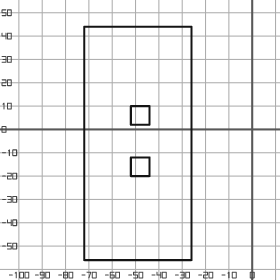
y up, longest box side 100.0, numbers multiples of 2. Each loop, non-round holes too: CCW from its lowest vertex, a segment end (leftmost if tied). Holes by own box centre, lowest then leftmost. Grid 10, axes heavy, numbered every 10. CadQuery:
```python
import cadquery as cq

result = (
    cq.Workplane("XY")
    .moveTo(-72.0, -56.0)
    .lineTo(-26.0, -56.0)
    .lineTo(-26.0, 44.0)
    .lineTo(-72.0, 44.0)
    .close()
    .moveTo(-52.0, -20.0)
    .lineTo(-44.0, -20.0)
    .lineTo(-44.0, -12.0)
    .lineTo(-52.0, -12.0)
    .close()
    .moveTo(-52.0, 2.0)
    .lineTo(-44.0, 2.0)
    .lineTo(-44.0, 10.0)
    .lineTo(-52.0, 10.0)
    .close()
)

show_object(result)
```